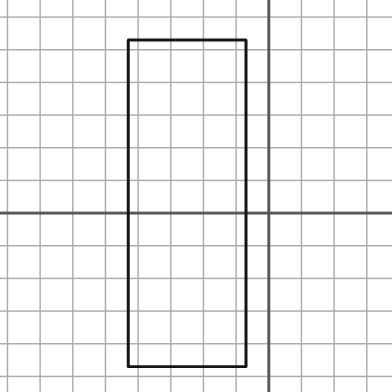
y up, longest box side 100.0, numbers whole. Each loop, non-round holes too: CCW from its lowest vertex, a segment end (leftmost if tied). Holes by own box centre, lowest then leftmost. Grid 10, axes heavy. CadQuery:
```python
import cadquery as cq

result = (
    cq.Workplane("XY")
    .moveTo(-43.0, -47.0)
    .lineTo(-7.0, -47.0)
    .lineTo(-7.0, 53.0)
    .lineTo(-43.0, 53.0)
    .close()
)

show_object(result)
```